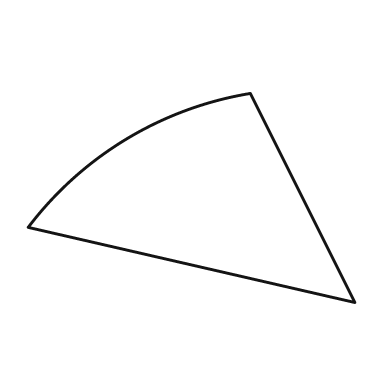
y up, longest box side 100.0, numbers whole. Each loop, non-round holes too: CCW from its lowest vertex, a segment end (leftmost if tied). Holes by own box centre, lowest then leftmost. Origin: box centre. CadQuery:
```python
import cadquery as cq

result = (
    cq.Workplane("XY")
    .moveTo(50.0, -32.0)
    .lineTo(18.0, 32.0)
    .threePointArc((-20.0, 18.0), (-50.0, -9.0))
    .close()
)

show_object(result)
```